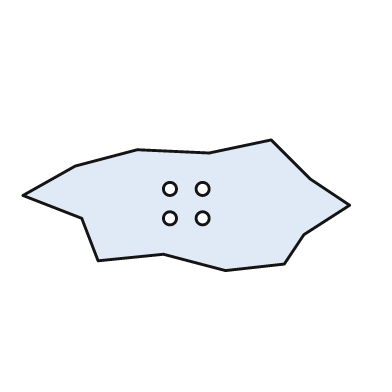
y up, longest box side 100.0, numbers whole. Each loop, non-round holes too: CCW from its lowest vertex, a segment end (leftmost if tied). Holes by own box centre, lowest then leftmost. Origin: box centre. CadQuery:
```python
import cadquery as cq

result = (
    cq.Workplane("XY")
    .moveTo(12.0, -20.0)
    .lineTo(30.0, -18.0)
    .lineTo(36.0, -9.0)
    .lineTo(50.0, 0.0)
    .lineTo(38.0, 8.0)
    .lineTo(26.0, 20.0)
    .lineTo(7.0, 16.0)
    .lineTo(-15.0, 17.0)
    .lineTo(-34.0, 12.0)
    .lineTo(-50.0, 3.0)
    .lineTo(-32.0, -4.0)
    .lineTo(-27.0, -17.0)
    .lineTo(-7.0, -15.0)
    .close()
    .moveTo(-5.0, -4.0)
    .circle(2.0)
    .moveTo(5.0, -4.0)
    .circle(2.0)
    .moveTo(-5.0, 5.0)
    .circle(2.0)
    .moveTo(5.0, 5.0)
    .circle(2.0)
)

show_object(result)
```